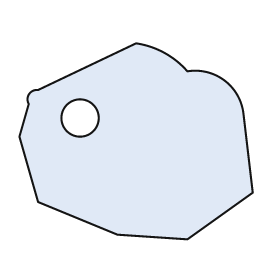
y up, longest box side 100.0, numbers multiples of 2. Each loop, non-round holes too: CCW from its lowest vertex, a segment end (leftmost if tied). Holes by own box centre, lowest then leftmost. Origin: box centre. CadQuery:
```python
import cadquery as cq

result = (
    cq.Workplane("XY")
    .moveTo(22.0, -42.0)
    .lineTo(50.0, -22.0)
    .lineTo(46.0, 12.0)
    .threePointArc((38.0, 26.0), (22.0, 30.0))
    .threePointArc((12.0, 38.0), (0.0, 42.0))
    .lineTo(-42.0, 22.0)
    .threePointArc((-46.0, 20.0), (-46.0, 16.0))
    .lineTo(-50.0, 2.0)
    .lineTo(-42.0, -26.0)
    .lineTo(-8.0, -40.0)
    .close()
    .moveTo(-24.0, 10.0)
    .circle(8.0)
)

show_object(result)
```